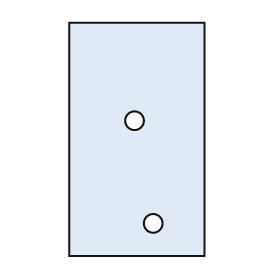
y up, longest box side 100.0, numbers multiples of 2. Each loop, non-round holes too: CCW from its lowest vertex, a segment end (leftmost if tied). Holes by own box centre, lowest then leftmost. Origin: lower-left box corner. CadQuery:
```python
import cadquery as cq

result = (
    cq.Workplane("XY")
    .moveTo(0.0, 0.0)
    .lineTo(58.0, 0.0)
    .lineTo(58.0, 100.0)
    .lineTo(0.0, 100.0)
    .close()
    .moveTo(36.0, 14.0)
    .circle(4.0)
    .moveTo(28.0, 58.0)
    .circle(4.0)
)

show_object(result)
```